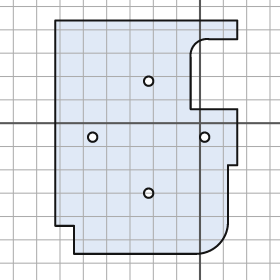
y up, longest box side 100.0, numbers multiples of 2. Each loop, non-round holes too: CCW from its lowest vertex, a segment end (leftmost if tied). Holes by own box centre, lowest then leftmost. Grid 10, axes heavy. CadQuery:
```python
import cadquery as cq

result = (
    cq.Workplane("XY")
    .moveTo(-54.0, -56.0)
    .lineTo(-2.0, -56.0)
    .threePointArc((8.0, -52.0), (12.0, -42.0))
    .lineTo(12.0, -18.0)
    .lineTo(16.0, -18.0)
    .lineTo(16.0, 6.0)
    .lineTo(-4.0, 6.0)
    .lineTo(-4.0, 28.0)
    .threePointArc((-2.0, 34.0), (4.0, 36.0))
    .lineTo(16.0, 36.0)
    .lineTo(16.0, 44.0)
    .lineTo(-62.0, 44.0)
    .lineTo(-62.0, -44.0)
    .lineTo(-54.0, -44.0)
    .close()
    .moveTo(-22.0, -30.0)
    .circle(2.0)
    .moveTo(-46.0, -6.0)
    .circle(2.0)
    .moveTo(2.0, -6.0)
    .circle(2.0)
    .moveTo(-22.0, 18.0)
    .circle(2.0)
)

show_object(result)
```